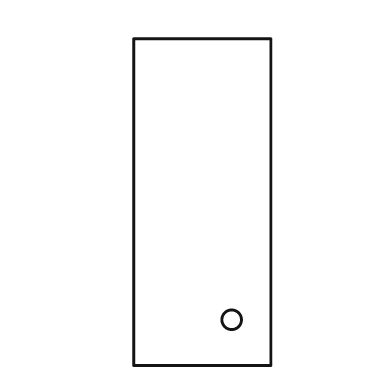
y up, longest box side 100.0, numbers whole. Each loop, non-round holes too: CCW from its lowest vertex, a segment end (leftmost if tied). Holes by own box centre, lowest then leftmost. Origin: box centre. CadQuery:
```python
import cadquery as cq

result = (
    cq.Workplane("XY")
    .moveTo(-21.0, -50.0)
    .lineTo(21.0, -50.0)
    .lineTo(21.0, 50.0)
    .lineTo(-21.0, 50.0)
    .close()
    .moveTo(9.0, -36.0)
    .circle(3.0)
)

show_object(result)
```